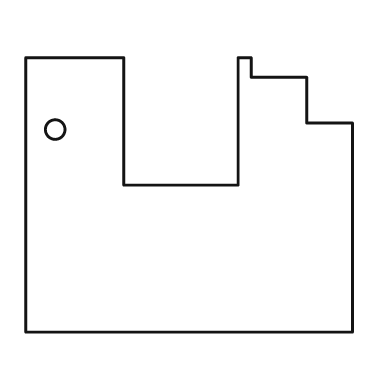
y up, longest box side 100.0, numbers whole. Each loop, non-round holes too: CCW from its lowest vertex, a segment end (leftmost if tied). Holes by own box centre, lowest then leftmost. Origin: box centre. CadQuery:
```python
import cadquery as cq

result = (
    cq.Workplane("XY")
    .moveTo(-50.0, -42.0)
    .lineTo(50.0, -42.0)
    .lineTo(50.0, 22.0)
    .lineTo(36.0, 22.0)
    .lineTo(36.0, 36.0)
    .lineTo(19.0, 36.0)
    .lineTo(19.0, 42.0)
    .lineTo(15.0, 42.0)
    .lineTo(15.0, 3.0)
    .lineTo(-20.0, 3.0)
    .lineTo(-20.0, 42.0)
    .lineTo(-50.0, 42.0)
    .close()
    .moveTo(-41.0, 20.0)
    .circle(3.0)
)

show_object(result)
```